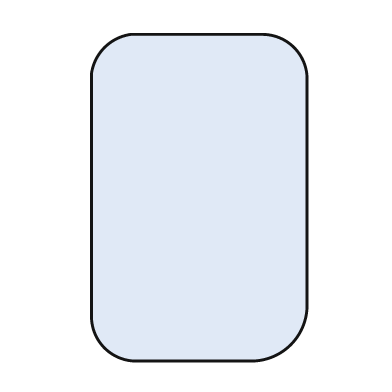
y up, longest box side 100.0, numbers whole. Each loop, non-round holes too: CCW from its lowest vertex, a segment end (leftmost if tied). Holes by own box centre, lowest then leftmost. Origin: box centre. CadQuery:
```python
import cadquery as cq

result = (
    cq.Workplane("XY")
    .moveTo(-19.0, -50.0)
    .lineTo(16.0, -50.0)
    .threePointArc((28.0, -45.0), (33.0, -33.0))
    .lineTo(33.0, 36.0)
    .threePointArc((29.0, 46.0), (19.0, 50.0))
    .lineTo(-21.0, 50.0)
    .threePointArc((-29.0, 46.0), (-33.0, 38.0))
    .lineTo(-33.0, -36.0)
    .threePointArc((-29.0, -46.0), (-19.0, -50.0))
    .close()
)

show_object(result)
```